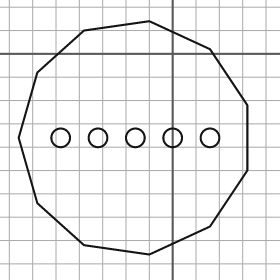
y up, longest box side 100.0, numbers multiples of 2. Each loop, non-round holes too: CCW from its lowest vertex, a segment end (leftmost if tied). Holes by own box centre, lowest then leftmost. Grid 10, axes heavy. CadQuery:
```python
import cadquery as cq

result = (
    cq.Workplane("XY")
    .moveTo(-10.0, -86.0)
    .lineTo(16.0, -74.0)
    .lineTo(32.0, -50.0)
    .lineTo(32.0, -22.0)
    .lineTo(16.0, 2.0)
    .lineTo(-10.0, 14.0)
    .lineTo(-38.0, 10.0)
    .lineTo(-58.0, -8.0)
    .lineTo(-66.0, -36.0)
    .lineTo(-58.0, -64.0)
    .lineTo(-38.0, -82.0)
    .close()
    .moveTo(-48.0, -36.0)
    .circle(4.0)
    .moveTo(-32.0, -36.0)
    .circle(4.0)
    .moveTo(-16.0, -36.0)
    .circle(4.0)
    .moveTo(0.0, -36.0)
    .circle(4.0)
    .moveTo(16.0, -36.0)
    .circle(4.0)
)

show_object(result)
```